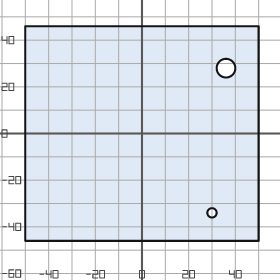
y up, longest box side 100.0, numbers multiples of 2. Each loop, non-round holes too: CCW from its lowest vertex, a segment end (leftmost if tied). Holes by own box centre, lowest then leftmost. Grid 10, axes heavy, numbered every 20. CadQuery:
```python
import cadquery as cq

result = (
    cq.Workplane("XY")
    .moveTo(-50.0, -46.0)
    .lineTo(50.0, -46.0)
    .lineTo(50.0, 46.0)
    .lineTo(-50.0, 46.0)
    .close()
    .moveTo(30.0, -34.0)
    .circle(2.0)
    .moveTo(36.0, 28.0)
    .circle(4.0)
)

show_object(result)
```